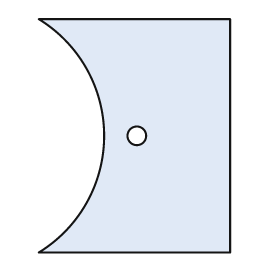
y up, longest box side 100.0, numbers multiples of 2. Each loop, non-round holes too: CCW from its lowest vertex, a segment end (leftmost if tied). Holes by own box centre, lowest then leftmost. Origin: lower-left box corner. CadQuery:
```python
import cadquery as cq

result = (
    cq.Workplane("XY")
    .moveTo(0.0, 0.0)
    .lineTo(82.0, 0.0)
    .lineTo(82.0, 100.0)
    .lineTo(0.0, 100.0)
    .threePointArc((28.0, 50.0), (0.0, 0.0))
    .close()
    .moveTo(42.0, 50.0)
    .circle(4.0)
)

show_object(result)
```